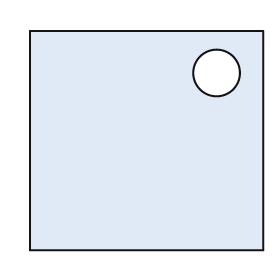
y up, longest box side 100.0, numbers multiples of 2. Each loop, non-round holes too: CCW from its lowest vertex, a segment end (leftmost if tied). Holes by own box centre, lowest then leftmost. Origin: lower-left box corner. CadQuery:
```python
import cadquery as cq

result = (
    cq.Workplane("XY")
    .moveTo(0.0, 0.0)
    .lineTo(100.0, 0.0)
    .lineTo(100.0, 94.0)
    .lineTo(0.0, 94.0)
    .close()
    .moveTo(80.0, 76.0)
    .circle(10.0)
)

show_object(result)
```